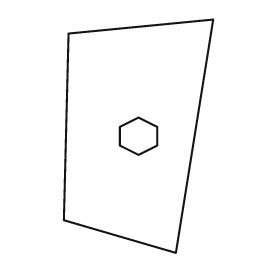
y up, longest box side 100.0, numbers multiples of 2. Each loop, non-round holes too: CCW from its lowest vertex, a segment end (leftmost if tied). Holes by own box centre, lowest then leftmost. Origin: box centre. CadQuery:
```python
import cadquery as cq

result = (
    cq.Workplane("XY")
    .moveTo(16.0, -50.0)
    .lineTo(32.0, 50.0)
    .lineTo(-30.0, 44.0)
    .lineTo(-32.0, -36.0)
    .close()
    .moveTo(0.0, -8.0)
    .lineTo(8.0, -4.0)
    .lineTo(8.0, 4.0)
    .lineTo(0.0, 8.0)
    .lineTo(-8.0, 4.0)
    .lineTo(-8.0, -4.0)
    .close()
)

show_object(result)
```